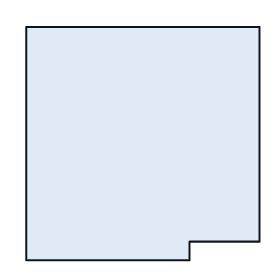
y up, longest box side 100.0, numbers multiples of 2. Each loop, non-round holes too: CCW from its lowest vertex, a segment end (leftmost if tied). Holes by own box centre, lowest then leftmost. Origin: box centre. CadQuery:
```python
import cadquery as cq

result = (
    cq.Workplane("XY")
    .moveTo(-50.0, -50.0)
    .lineTo(20.0, -50.0)
    .lineTo(20.0, -42.0)
    .lineTo(50.0, -42.0)
    .lineTo(50.0, 50.0)
    .lineTo(-50.0, 50.0)
    .close()
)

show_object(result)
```